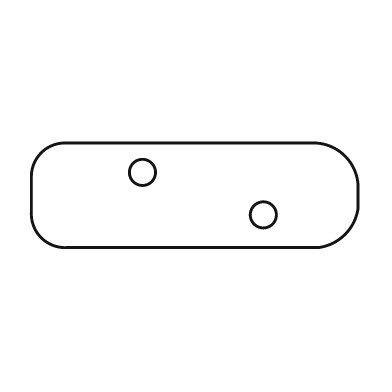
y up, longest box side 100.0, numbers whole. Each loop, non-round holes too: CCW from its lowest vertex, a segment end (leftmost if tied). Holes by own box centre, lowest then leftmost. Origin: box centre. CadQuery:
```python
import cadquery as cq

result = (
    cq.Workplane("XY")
    .moveTo(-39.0, -16.0)
    .lineTo(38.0, -16.0)
    .threePointArc((46.0, -12.0), (50.0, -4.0))
    .lineTo(50.0, 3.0)
    .threePointArc((46.0, 12.0), (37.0, 16.0))
    .lineTo(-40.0, 16.0)
    .threePointArc((-47.0, 13.0), (-50.0, 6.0))
    .lineTo(-50.0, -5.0)
    .threePointArc((-47.0, -13.0), (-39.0, -16.0))
    .close()
    .moveTo(21.0, -6.0)
    .circle(4.0)
    .moveTo(-16.0, 7.0)
    .circle(4.0)
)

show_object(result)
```